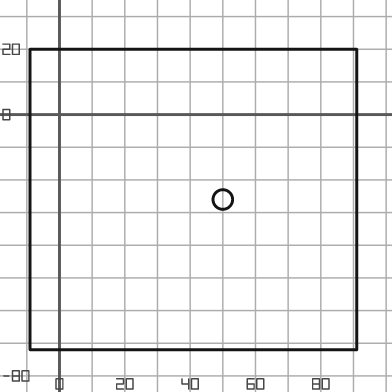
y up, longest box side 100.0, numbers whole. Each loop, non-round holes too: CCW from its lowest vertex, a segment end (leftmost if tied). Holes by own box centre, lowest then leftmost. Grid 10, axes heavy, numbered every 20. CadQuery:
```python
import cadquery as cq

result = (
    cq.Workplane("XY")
    .moveTo(-9.0, -72.0)
    .lineTo(91.0, -72.0)
    .lineTo(91.0, 20.0)
    .lineTo(-9.0, 20.0)
    .close()
    .moveTo(50.0, -26.0)
    .circle(3.0)
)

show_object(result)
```